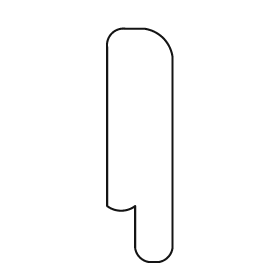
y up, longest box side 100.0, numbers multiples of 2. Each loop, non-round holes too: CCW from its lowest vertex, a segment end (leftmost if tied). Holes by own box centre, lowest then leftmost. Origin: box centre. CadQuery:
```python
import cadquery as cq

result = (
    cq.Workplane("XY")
    .moveTo(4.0, -50.0)
    .lineTo(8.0, -50.0)
    .threePointArc((12.0, -48.0), (14.0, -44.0))
    .lineTo(14.0, 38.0)
    .threePointArc((10.0, 46.0), (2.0, 50.0))
    .lineTo(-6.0, 50.0)
    .threePointArc((-12.0, 48.0), (-14.0, 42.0))
    .lineTo(-14.0, -26.0)
    .threePointArc((-8.0, -28.0), (-2.0, -26.0))
    .lineTo(-2.0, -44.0)
    .threePointArc((0.0, -48.0), (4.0, -50.0))
    .close()
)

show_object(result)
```